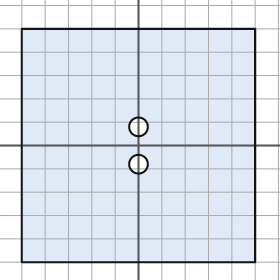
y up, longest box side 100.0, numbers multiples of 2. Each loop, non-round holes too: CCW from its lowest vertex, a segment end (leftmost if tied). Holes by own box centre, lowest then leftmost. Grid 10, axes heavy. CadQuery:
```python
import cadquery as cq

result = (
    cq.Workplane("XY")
    .moveTo(-50.0, -50.0)
    .lineTo(50.0, -50.0)
    .lineTo(50.0, 50.0)
    .lineTo(-50.0, 50.0)
    .close()
    .moveTo(0.0, -8.0)
    .circle(4.0)
    .moveTo(0.0, 8.0)
    .circle(4.0)
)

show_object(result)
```